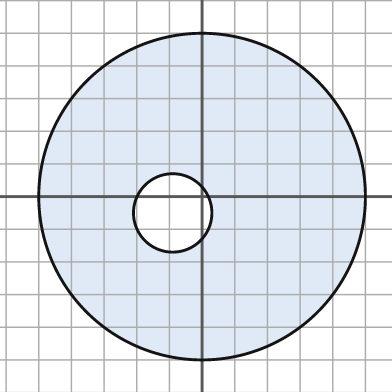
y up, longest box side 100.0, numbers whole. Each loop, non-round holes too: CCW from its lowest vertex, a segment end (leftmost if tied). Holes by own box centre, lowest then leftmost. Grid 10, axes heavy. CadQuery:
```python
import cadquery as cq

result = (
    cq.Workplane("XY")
    .moveTo(0.0, 0.0)
    .circle(50.0)
    .moveTo(-9.0, -5.0)
    .circle(12.0)
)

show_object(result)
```